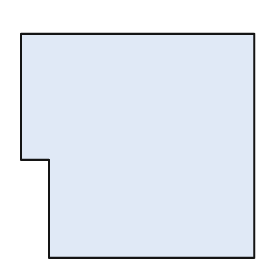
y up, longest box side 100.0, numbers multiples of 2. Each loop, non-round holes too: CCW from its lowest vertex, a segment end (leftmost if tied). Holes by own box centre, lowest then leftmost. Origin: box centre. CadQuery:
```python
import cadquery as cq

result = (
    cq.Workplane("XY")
    .moveTo(-38.0, -48.0)
    .lineTo(50.0, -48.0)
    .lineTo(50.0, 48.0)
    .lineTo(-50.0, 48.0)
    .lineTo(-50.0, -6.0)
    .lineTo(-38.0, -6.0)
    .close()
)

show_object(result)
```